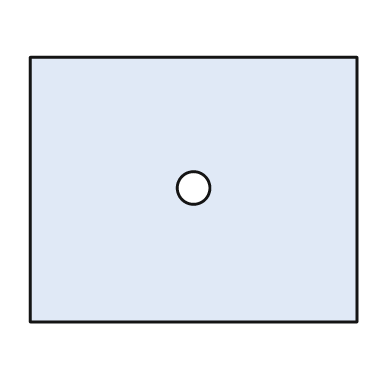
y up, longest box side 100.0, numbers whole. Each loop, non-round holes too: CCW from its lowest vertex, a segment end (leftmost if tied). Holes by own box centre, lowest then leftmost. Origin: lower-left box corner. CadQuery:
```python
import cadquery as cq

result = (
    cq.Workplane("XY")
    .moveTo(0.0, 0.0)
    .lineTo(100.0, 0.0)
    .lineTo(100.0, 81.0)
    .lineTo(0.0, 81.0)
    .close()
    .moveTo(50.0, 41.0)
    .circle(5.0)
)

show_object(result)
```